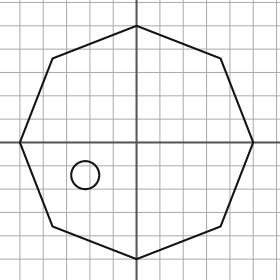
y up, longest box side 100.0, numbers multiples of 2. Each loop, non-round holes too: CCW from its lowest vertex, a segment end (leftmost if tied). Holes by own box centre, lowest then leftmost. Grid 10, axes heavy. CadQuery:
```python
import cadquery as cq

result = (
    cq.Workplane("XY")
    .moveTo(0.0, -50.0)
    .lineTo(36.0, -36.0)
    .lineTo(50.0, 0.0)
    .lineTo(36.0, 36.0)
    .lineTo(0.0, 50.0)
    .lineTo(-36.0, 36.0)
    .lineTo(-50.0, 0.0)
    .lineTo(-36.0, -36.0)
    .close()
    .moveTo(-22.0, -14.0)
    .circle(6.0)
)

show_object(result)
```